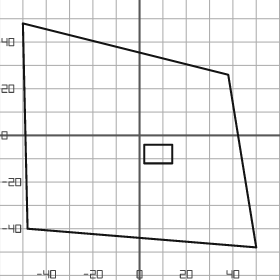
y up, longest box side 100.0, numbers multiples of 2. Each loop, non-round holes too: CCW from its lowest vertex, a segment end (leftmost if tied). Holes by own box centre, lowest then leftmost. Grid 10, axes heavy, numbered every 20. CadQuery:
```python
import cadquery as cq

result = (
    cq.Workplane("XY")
    .moveTo(50.0, -48.0)
    .lineTo(38.0, 26.0)
    .lineTo(-50.0, 48.0)
    .lineTo(-48.0, -40.0)
    .close()
    .moveTo(2.0, -12.0)
    .lineTo(14.0, -12.0)
    .lineTo(14.0, -4.0)
    .lineTo(2.0, -4.0)
    .close()
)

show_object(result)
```